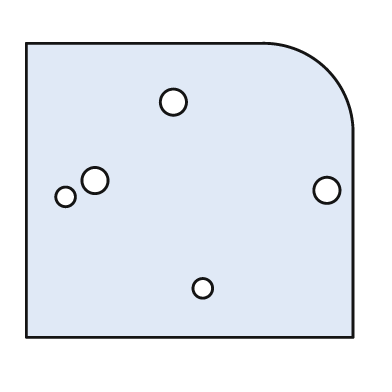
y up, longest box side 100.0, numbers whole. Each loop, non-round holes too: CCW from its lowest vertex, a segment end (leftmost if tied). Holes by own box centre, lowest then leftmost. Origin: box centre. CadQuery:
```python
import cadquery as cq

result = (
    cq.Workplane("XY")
    .moveTo(-50.0, -45.0)
    .lineTo(50.0, -45.0)
    .lineTo(50.0, 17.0)
    .threePointArc((42.0, 37.0), (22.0, 45.0))
    .lineTo(-50.0, 45.0)
    .close()
    .moveTo(4.0, -30.0)
    .circle(3.0)
    .moveTo(-38.0, -2.0)
    .circle(3.0)
    .moveTo(42.0, 0.0)
    .circle(4.0)
    .moveTo(-29.0, 3.0)
    .circle(4.0)
    .moveTo(-5.0, 27.0)
    .circle(4.0)
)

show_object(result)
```